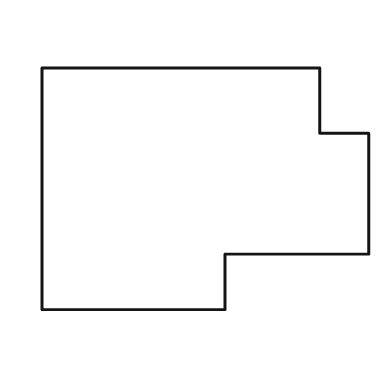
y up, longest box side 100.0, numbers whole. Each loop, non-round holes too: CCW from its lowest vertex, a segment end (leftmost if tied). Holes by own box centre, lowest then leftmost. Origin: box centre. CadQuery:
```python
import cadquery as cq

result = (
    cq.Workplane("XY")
    .moveTo(-50.0, -37.0)
    .lineTo(6.0, -37.0)
    .lineTo(6.0, -20.0)
    .lineTo(50.0, -20.0)
    .lineTo(50.0, 17.0)
    .lineTo(35.0, 17.0)
    .lineTo(35.0, 37.0)
    .lineTo(-50.0, 37.0)
    .close()
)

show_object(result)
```